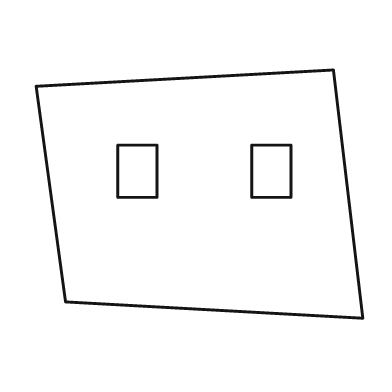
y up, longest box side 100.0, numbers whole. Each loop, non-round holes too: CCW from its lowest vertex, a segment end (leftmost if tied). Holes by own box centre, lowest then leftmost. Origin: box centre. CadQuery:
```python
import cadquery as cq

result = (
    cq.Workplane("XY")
    .moveTo(50.0, -38.0)
    .lineTo(41.0, 38.0)
    .lineTo(-50.0, 33.0)
    .lineTo(-41.0, -33.0)
    .close()
    .moveTo(-25.0, -1.0)
    .lineTo(-13.0, -1.0)
    .lineTo(-13.0, 15.0)
    .lineTo(-25.0, 15.0)
    .close()
    .moveTo(16.0, -1.0)
    .lineTo(28.0, -1.0)
    .lineTo(28.0, 15.0)
    .lineTo(16.0, 15.0)
    .close()
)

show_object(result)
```